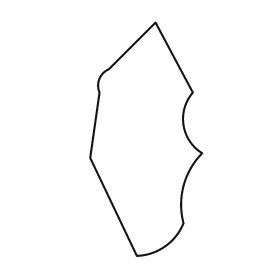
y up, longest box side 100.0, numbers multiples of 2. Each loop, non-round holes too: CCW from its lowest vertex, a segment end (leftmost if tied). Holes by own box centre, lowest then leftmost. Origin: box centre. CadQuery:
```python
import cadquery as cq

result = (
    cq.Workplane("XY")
    .moveTo(-4.0, -50.0)
    .threePointArc((8.0, -46.0), (16.0, -36.0))
    .threePointArc((16.0, -20.0), (24.0, -6.0))
    .threePointArc((16.0, 6.0), (20.0, 20.0))
    .lineTo(4.0, 50.0)
    .lineTo(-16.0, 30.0)
    .threePointArc((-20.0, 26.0), (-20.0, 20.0))
    .lineTo(-24.0, -8.0)
    .close()
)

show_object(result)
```